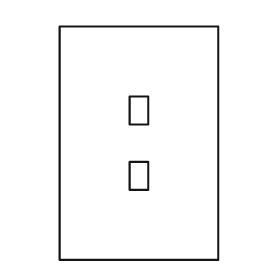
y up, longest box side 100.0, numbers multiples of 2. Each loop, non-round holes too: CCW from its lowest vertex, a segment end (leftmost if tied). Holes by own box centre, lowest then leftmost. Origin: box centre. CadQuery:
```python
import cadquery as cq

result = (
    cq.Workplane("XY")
    .moveTo(-34.0, -50.0)
    .lineTo(34.0, -50.0)
    .lineTo(34.0, 50.0)
    .lineTo(-34.0, 50.0)
    .close()
    .moveTo(-4.0, -20.0)
    .lineTo(4.0, -20.0)
    .lineTo(4.0, -8.0)
    .lineTo(-4.0, -8.0)
    .close()
    .moveTo(-4.0, 8.0)
    .lineTo(4.0, 8.0)
    .lineTo(4.0, 20.0)
    .lineTo(-4.0, 20.0)
    .close()
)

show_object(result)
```